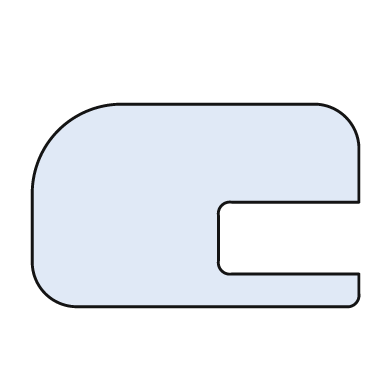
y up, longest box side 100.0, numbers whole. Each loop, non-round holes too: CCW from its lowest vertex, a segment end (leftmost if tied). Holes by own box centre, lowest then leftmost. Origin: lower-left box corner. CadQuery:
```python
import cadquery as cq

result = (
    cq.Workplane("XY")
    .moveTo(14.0, 0.0)
    .lineTo(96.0, 0.0)
    .threePointArc((99.0, 1.0), (100.0, 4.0))
    .lineTo(100.0, 10.0)
    .lineTo(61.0, 10.0)
    .threePointArc((58.0, 11.0), (57.0, 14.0))
    .lineTo(57.0, 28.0)
    .threePointArc((58.0, 31.0), (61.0, 32.0))
    .lineTo(100.0, 32.0)
    .lineTo(100.0, 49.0)
    .threePointArc((96.0, 58.0), (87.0, 62.0))
    .lineTo(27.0, 62.0)
    .threePointArc((8.0, 54.0), (0.0, 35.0))
    .lineTo(0.0, 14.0)
    .threePointArc((4.0, 4.0), (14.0, 0.0))
    .close()
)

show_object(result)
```